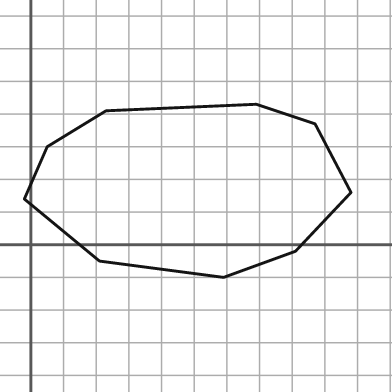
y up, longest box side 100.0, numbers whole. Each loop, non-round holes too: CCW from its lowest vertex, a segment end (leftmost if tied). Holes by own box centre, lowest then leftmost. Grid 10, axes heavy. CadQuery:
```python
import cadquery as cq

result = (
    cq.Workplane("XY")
    .moveTo(59.0, -10.0)
    .lineTo(81.0, -2.0)
    .lineTo(98.0, 16.0)
    .lineTo(87.0, 37.0)
    .lineTo(69.0, 43.0)
    .lineTo(23.0, 41.0)
    .lineTo(5.0, 30.0)
    .lineTo(-2.0, 14.0)
    .lineTo(21.0, -5.0)
    .close()
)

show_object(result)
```